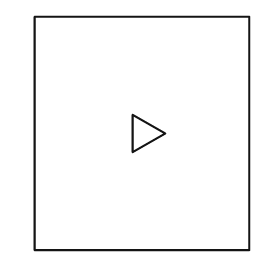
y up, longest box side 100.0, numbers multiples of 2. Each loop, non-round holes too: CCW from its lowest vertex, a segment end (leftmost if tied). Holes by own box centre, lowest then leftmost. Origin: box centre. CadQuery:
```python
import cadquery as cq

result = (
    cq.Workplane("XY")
    .moveTo(-46.0, -50.0)
    .lineTo(46.0, -50.0)
    .lineTo(46.0, 50.0)
    .lineTo(-46.0, 50.0)
    .close()
    .moveTo(-4.0, -8.0)
    .lineTo(10.0, 0.0)
    .lineTo(-4.0, 8.0)
    .close()
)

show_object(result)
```